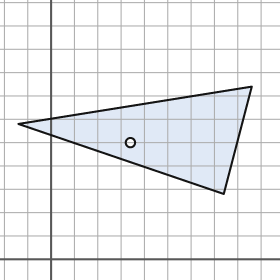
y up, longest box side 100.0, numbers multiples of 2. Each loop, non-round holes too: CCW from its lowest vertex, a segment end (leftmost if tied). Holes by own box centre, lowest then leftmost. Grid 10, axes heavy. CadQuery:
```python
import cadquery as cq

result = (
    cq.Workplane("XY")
    .moveTo(74.0, 28.0)
    .lineTo(86.0, 74.0)
    .lineTo(-14.0, 58.0)
    .close()
    .moveTo(34.0, 50.0)
    .circle(2.0)
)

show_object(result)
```